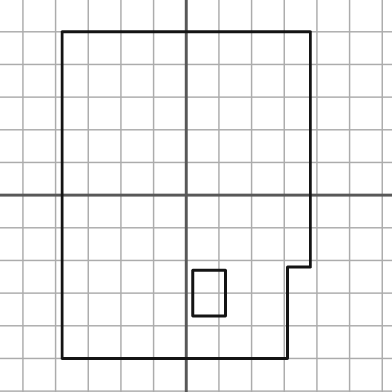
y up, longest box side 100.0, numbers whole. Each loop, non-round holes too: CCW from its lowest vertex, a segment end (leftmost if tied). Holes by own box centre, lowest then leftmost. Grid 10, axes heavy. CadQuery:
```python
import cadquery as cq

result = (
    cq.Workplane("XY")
    .moveTo(-38.0, -50.0)
    .lineTo(31.0, -50.0)
    .lineTo(31.0, -22.0)
    .lineTo(38.0, -22.0)
    .lineTo(38.0, 50.0)
    .lineTo(-38.0, 50.0)
    .close()
    .moveTo(2.0, -37.0)
    .lineTo(12.0, -37.0)
    .lineTo(12.0, -23.0)
    .lineTo(2.0, -23.0)
    .close()
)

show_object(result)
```